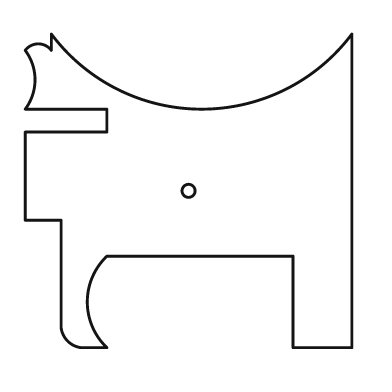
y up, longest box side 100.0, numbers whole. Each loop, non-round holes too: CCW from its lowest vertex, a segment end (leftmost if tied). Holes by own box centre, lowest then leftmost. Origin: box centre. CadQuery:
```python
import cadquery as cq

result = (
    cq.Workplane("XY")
    .moveTo(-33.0, -48.0)
    .lineTo(-25.0, -48.0)
    .threePointArc((-31.0, -34.0), (-25.0, -20.0))
    .lineTo(32.0, -20.0)
    .lineTo(32.0, -48.0)
    .lineTo(50.0, -48.0)
    .lineTo(50.0, 48.0)
    .threePointArc((4.0, 25.0), (-42.0, 48.0))
    .lineTo(-42.0, 43.0)
    .threePointArc((-46.0, 45.0), (-50.0, 43.0))
    .threePointArc((-47.0, 34.0), (-50.0, 25.0))
    .lineTo(-25.0, 25.0)
    .lineTo(-25.0, 18.0)
    .lineTo(-50.0, 18.0)
    .lineTo(-50.0, -9.0)
    .lineTo(-39.0, -9.0)
    .lineTo(-39.0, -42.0)
    .threePointArc((-37.0, -46.0), (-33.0, -48.0))
    .close()
    .moveTo(0.0, 0.0)
    .circle(2.0)
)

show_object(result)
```